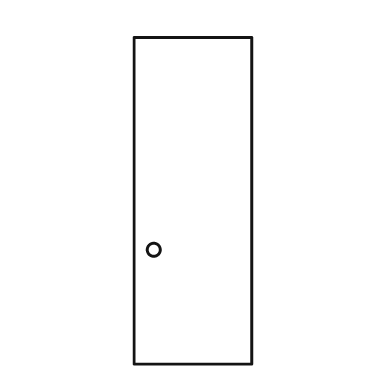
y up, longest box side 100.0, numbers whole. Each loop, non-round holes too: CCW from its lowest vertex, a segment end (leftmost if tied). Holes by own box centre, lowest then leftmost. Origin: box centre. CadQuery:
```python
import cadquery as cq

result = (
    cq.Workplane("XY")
    .moveTo(-18.0, -50.0)
    .lineTo(18.0, -50.0)
    .lineTo(18.0, 50.0)
    .lineTo(-18.0, 50.0)
    .close()
    .moveTo(-12.0, -15.0)
    .circle(2.0)
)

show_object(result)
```